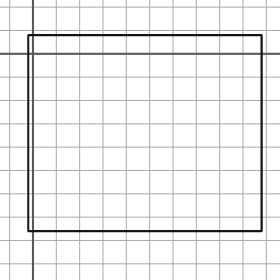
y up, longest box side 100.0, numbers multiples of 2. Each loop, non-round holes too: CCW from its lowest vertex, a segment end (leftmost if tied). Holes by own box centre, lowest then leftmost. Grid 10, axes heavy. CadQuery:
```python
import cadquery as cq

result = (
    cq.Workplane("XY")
    .moveTo(-2.0, -76.0)
    .lineTo(98.0, -76.0)
    .lineTo(98.0, 8.0)
    .lineTo(-2.0, 8.0)
    .close()
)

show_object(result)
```